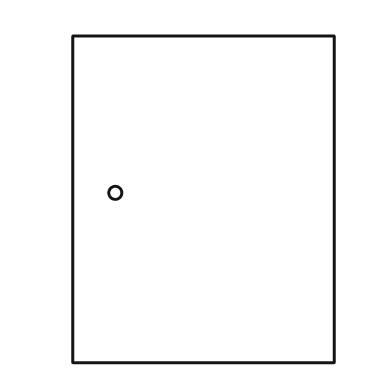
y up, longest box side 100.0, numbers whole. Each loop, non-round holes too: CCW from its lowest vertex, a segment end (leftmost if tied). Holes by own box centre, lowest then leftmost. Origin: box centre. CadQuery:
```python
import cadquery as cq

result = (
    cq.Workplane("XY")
    .moveTo(-40.0, -50.0)
    .lineTo(40.0, -50.0)
    .lineTo(40.0, 50.0)
    .lineTo(-40.0, 50.0)
    .close()
    .moveTo(-27.0, 2.0)
    .circle(2.0)
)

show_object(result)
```